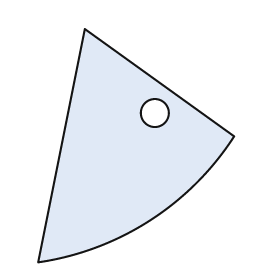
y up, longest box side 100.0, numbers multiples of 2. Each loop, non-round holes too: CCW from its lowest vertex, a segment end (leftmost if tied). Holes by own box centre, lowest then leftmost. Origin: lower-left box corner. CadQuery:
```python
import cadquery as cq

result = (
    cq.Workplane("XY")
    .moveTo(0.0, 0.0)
    .threePointArc((48.0, 18.0), (84.0, 54.0))
    .lineTo(20.0, 100.0)
    .close()
    .moveTo(50.0, 64.0)
    .circle(6.0)
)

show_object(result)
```